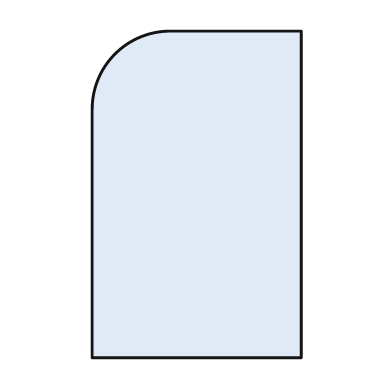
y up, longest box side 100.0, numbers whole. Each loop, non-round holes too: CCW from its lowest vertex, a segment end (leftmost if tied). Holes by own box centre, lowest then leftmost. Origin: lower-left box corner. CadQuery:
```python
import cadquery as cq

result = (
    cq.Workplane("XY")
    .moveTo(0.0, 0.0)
    .lineTo(64.0, 0.0)
    .lineTo(64.0, 100.0)
    .lineTo(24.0, 100.0)
    .threePointArc((7.0, 93.0), (0.0, 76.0))
    .close()
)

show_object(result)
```